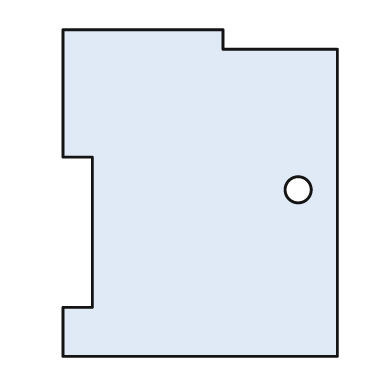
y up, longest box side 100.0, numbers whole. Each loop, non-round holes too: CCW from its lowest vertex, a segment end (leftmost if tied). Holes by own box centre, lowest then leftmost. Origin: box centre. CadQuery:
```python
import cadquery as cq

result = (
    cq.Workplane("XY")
    .moveTo(-42.0, -50.0)
    .lineTo(42.0, -50.0)
    .lineTo(42.0, 44.0)
    .lineTo(7.0, 44.0)
    .lineTo(7.0, 50.0)
    .lineTo(-42.0, 50.0)
    .lineTo(-42.0, 11.0)
    .lineTo(-33.0, 11.0)
    .lineTo(-33.0, -35.0)
    .lineTo(-42.0, -35.0)
    .close()
    .moveTo(30.0, 1.0)
    .circle(4.0)
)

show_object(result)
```